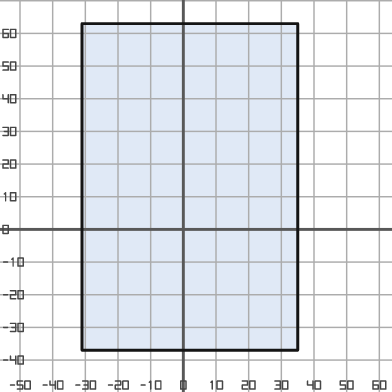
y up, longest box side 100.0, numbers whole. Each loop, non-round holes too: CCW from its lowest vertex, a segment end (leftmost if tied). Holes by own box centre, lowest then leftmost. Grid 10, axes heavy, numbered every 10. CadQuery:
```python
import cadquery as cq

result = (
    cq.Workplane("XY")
    .moveTo(-31.0, -37.0)
    .lineTo(35.0, -37.0)
    .lineTo(35.0, 63.0)
    .lineTo(-31.0, 63.0)
    .close()
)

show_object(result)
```